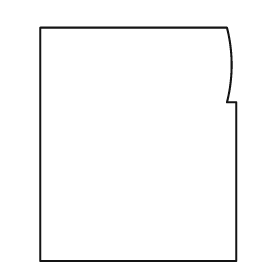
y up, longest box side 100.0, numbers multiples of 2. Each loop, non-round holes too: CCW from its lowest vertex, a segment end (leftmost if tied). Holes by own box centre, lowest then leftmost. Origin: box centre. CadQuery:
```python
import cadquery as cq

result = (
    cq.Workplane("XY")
    .moveTo(-42.0, -50.0)
    .lineTo(42.0, -50.0)
    .lineTo(42.0, 18.0)
    .lineTo(38.0, 18.0)
    .threePointArc((40.0, 34.0), (38.0, 50.0))
    .lineTo(-42.0, 50.0)
    .close()
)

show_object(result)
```